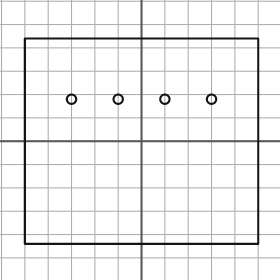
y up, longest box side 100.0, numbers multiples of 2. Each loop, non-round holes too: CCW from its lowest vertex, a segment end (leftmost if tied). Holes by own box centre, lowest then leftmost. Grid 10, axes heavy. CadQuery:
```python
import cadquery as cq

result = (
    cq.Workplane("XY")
    .moveTo(-50.0, -44.0)
    .lineTo(50.0, -44.0)
    .lineTo(50.0, 44.0)
    .lineTo(-50.0, 44.0)
    .close()
    .moveTo(-30.0, 18.0)
    .circle(2.0)
    .moveTo(-10.0, 18.0)
    .circle(2.0)
    .moveTo(10.0, 18.0)
    .circle(2.0)
    .moveTo(30.0, 18.0)
    .circle(2.0)
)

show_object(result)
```